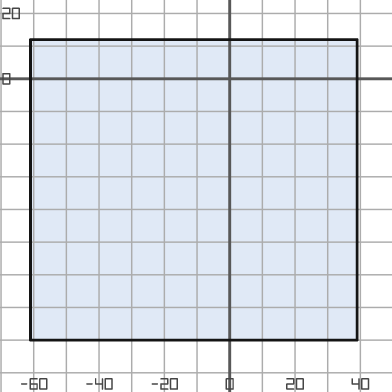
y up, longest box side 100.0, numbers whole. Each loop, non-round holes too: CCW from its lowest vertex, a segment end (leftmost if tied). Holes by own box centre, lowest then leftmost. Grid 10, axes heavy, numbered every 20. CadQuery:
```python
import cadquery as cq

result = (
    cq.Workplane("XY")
    .moveTo(-61.0, -80.0)
    .lineTo(39.0, -80.0)
    .lineTo(39.0, 12.0)
    .lineTo(-61.0, 12.0)
    .close()
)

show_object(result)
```